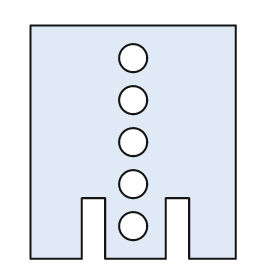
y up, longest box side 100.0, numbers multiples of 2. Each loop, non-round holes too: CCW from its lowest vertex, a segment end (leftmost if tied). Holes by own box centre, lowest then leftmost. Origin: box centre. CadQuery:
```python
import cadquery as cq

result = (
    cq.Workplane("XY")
    .moveTo(-44.0, -50.0)
    .lineTo(-22.0, -50.0)
    .lineTo(-22.0, -24.0)
    .lineTo(-12.0, -24.0)
    .lineTo(-12.0, -50.0)
    .lineTo(14.0, -50.0)
    .lineTo(14.0, -24.0)
    .lineTo(24.0, -24.0)
    .lineTo(24.0, -50.0)
    .lineTo(44.0, -50.0)
    .lineTo(44.0, 50.0)
    .lineTo(-44.0, 50.0)
    .close()
    .moveTo(0.0, -36.0)
    .circle(6.0)
    .moveTo(0.0, -18.0)
    .circle(6.0)
    .moveTo(0.0, 0.0)
    .circle(6.0)
    .moveTo(0.0, 18.0)
    .circle(6.0)
    .moveTo(0.0, 36.0)
    .circle(6.0)
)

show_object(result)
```